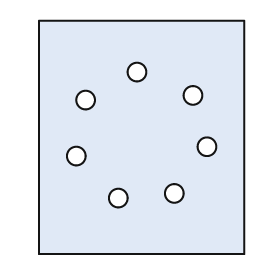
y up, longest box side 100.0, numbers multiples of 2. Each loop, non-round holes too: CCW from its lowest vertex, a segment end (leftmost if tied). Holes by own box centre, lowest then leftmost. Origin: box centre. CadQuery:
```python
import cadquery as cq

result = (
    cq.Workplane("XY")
    .moveTo(-44.0, -50.0)
    .lineTo(44.0, -50.0)
    .lineTo(44.0, 50.0)
    .lineTo(-44.0, 50.0)
    .close()
    .moveTo(-10.0, -26.0)
    .circle(4.0)
    .moveTo(14.0, -24.0)
    .circle(4.0)
    .moveTo(-28.0, -8.0)
    .circle(4.0)
    .moveTo(28.0, -4.0)
    .circle(4.0)
    .moveTo(-24.0, 16.0)
    .circle(4.0)
    .moveTo(22.0, 18.0)
    .circle(4.0)
    .moveTo(-2.0, 28.0)
    .circle(4.0)
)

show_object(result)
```